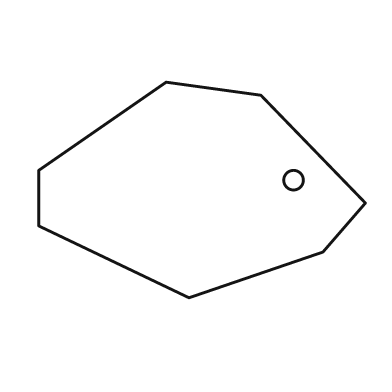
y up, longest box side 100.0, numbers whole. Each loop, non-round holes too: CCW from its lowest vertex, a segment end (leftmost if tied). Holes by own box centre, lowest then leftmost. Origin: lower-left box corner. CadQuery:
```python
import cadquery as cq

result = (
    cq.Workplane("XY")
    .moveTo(46.0, 0.0)
    .lineTo(87.0, 14.0)
    .lineTo(100.0, 29.0)
    .lineTo(68.0, 62.0)
    .lineTo(39.0, 66.0)
    .lineTo(0.0, 39.0)
    .lineTo(0.0, 22.0)
    .close()
    .moveTo(78.0, 36.0)
    .circle(3.0)
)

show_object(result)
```